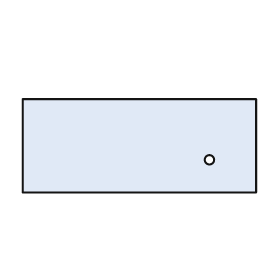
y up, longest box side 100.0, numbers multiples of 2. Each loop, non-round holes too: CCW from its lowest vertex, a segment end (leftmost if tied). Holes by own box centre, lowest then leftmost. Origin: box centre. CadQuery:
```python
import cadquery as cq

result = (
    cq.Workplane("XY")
    .moveTo(-50.0, -20.0)
    .lineTo(50.0, -20.0)
    .lineTo(50.0, 20.0)
    .lineTo(-50.0, 20.0)
    .close()
    .moveTo(30.0, -6.0)
    .circle(2.0)
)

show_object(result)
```